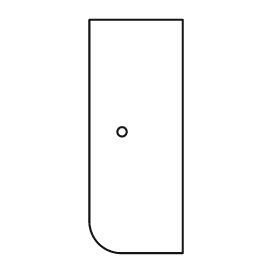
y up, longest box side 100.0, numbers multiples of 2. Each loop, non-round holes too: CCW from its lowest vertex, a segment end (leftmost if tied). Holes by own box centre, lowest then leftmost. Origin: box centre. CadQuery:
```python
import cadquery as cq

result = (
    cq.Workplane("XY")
    .moveTo(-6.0, -50.0)
    .lineTo(20.0, -50.0)
    .lineTo(20.0, 50.0)
    .lineTo(-20.0, 50.0)
    .lineTo(-20.0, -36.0)
    .threePointArc((-16.0, -46.0), (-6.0, -50.0))
    .close()
    .moveTo(-6.0, 2.0)
    .circle(2.0)
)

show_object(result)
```